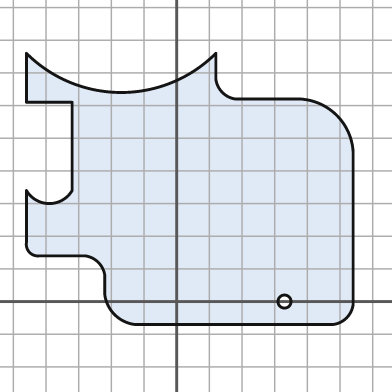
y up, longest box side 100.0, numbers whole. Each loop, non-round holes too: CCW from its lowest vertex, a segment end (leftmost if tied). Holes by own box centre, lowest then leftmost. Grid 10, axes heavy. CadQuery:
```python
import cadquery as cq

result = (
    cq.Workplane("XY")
    .moveTo(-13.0, -7.0)
    .lineTo(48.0, -7.0)
    .threePointArc((52.0, -5.0), (54.0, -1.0))
    .lineTo(54.0, 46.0)
    .threePointArc((49.0, 57.0), (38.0, 62.0))
    .lineTo(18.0, 62.0)
    .threePointArc((14.0, 64.0), (12.0, 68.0))
    .lineTo(12.0, 76.0)
    .threePointArc((-17.0, 64.0), (-46.0, 76.0))
    .lineTo(-46.0, 61.0)
    .lineTo(-32.0, 61.0)
    .lineTo(-32.0, 34.0)
    .threePointArc((-39.0, 30.0), (-46.0, 34.0))
    .lineTo(-46.0, 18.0)
    .threePointArc((-45.0, 15.0), (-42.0, 14.0))
    .lineTo(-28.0, 14.0)
    .threePointArc((-24.0, 12.0), (-22.0, 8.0))
    .lineTo(-22.0, 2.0)
    .threePointArc((-19.0, -4.0), (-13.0, -7.0))
    .close()
    .moveTo(33.0, 0.0)
    .circle(2.0)
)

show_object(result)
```